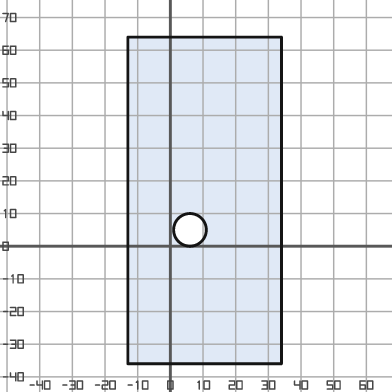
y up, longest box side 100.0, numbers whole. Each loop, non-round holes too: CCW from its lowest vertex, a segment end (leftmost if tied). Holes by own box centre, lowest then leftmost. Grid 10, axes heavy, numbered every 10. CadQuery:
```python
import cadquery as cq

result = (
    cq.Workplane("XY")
    .moveTo(-13.0, -36.0)
    .lineTo(34.0, -36.0)
    .lineTo(34.0, 64.0)
    .lineTo(-13.0, 64.0)
    .close()
    .moveTo(6.0, 5.0)
    .circle(5.0)
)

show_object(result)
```